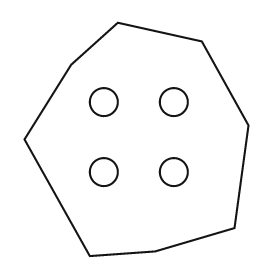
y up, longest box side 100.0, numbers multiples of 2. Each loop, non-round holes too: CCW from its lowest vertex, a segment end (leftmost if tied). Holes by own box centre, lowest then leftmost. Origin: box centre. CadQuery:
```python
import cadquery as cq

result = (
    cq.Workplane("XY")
    .moveTo(-20.0, -50.0)
    .lineTo(8.0, -48.0)
    .lineTo(42.0, -38.0)
    .lineTo(48.0, 6.0)
    .lineTo(28.0, 42.0)
    .lineTo(-8.0, 50.0)
    .lineTo(-28.0, 32.0)
    .lineTo(-48.0, 0.0)
    .close()
    .moveTo(-14.0, -14.0)
    .circle(6.0)
    .moveTo(16.0, -14.0)
    .circle(6.0)
    .moveTo(-14.0, 16.0)
    .circle(6.0)
    .moveTo(16.0, 16.0)
    .circle(6.0)
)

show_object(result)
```